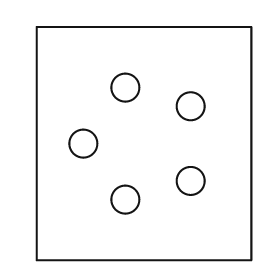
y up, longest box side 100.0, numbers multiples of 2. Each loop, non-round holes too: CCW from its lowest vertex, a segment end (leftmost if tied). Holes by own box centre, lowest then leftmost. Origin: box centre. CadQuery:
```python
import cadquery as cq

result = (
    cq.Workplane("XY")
    .moveTo(-46.0, -50.0)
    .lineTo(46.0, -50.0)
    .lineTo(46.0, 50.0)
    .lineTo(-46.0, 50.0)
    .close()
    .moveTo(-8.0, -24.0)
    .circle(6.0)
    .moveTo(20.0, -16.0)
    .circle(6.0)
    .moveTo(-26.0, 0.0)
    .circle(6.0)
    .moveTo(20.0, 16.0)
    .circle(6.0)
    .moveTo(-8.0, 24.0)
    .circle(6.0)
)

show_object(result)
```